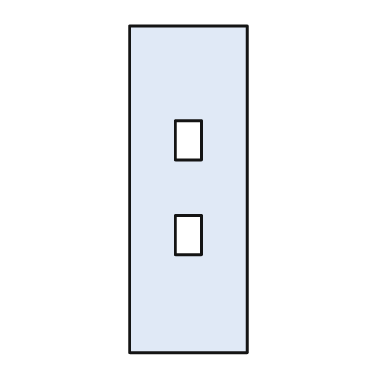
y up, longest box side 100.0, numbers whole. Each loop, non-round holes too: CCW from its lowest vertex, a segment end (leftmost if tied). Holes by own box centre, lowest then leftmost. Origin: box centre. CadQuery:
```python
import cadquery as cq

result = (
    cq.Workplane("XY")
    .moveTo(-18.0, -50.0)
    .lineTo(18.0, -50.0)
    .lineTo(18.0, 50.0)
    .lineTo(-18.0, 50.0)
    .close()
    .moveTo(-4.0, -20.0)
    .lineTo(4.0, -20.0)
    .lineTo(4.0, -8.0)
    .lineTo(-4.0, -8.0)
    .close()
    .moveTo(-4.0, 9.0)
    .lineTo(4.0, 9.0)
    .lineTo(4.0, 21.0)
    .lineTo(-4.0, 21.0)
    .close()
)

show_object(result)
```